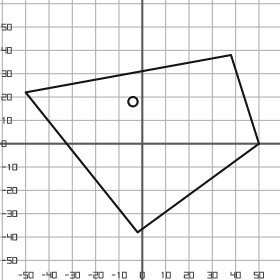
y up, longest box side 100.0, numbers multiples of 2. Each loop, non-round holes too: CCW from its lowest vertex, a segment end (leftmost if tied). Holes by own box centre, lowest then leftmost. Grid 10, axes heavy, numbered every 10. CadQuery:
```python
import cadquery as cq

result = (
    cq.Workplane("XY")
    .moveTo(-2.0, -38.0)
    .lineTo(50.0, 0.0)
    .lineTo(38.0, 38.0)
    .lineTo(-50.0, 22.0)
    .close()
    .moveTo(-4.0, 18.0)
    .circle(2.0)
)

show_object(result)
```